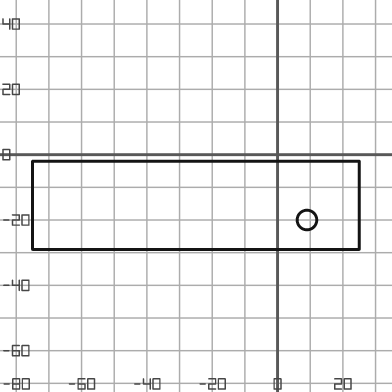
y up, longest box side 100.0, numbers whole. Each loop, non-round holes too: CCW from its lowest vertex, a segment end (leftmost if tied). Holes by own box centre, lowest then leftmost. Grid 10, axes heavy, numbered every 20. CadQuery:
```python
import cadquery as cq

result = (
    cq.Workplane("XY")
    .moveTo(-75.0, -29.0)
    .lineTo(25.0, -29.0)
    .lineTo(25.0, -2.0)
    .lineTo(-75.0, -2.0)
    .close()
    .moveTo(9.0, -20.0)
    .circle(3.0)
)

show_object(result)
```